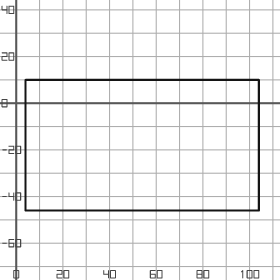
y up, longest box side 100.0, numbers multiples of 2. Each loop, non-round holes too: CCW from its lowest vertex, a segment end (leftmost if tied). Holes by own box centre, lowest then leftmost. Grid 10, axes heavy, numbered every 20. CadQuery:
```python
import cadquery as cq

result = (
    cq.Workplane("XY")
    .moveTo(4.0, -46.0)
    .lineTo(104.0, -46.0)
    .lineTo(104.0, 10.0)
    .lineTo(4.0, 10.0)
    .close()
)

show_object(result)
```